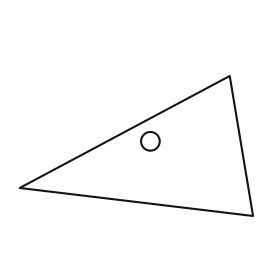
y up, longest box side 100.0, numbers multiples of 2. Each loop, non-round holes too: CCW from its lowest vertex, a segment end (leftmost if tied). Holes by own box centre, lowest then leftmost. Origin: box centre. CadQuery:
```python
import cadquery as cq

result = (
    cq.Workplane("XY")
    .moveTo(50.0, -30.0)
    .lineTo(40.0, 30.0)
    .lineTo(-50.0, -18.0)
    .close()
    .moveTo(6.0, 2.0)
    .circle(4.0)
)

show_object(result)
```